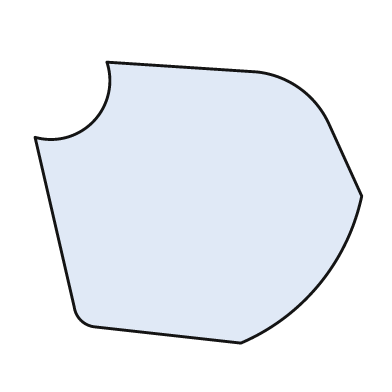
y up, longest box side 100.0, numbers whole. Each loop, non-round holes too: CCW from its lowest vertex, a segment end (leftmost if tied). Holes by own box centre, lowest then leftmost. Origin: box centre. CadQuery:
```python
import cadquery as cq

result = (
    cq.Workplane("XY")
    .moveTo(13.0, -43.0)
    .threePointArc((37.0, -25.0), (50.0, 2.0))
    .lineTo(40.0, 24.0)
    .threePointArc((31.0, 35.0), (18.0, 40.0))
    .lineTo(-28.0, 43.0)
    .threePointArc((-32.0, 25.0), (-50.0, 20.0))
    .lineTo(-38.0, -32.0)
    .threePointArc((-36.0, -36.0), (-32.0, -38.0))
    .close()
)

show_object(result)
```